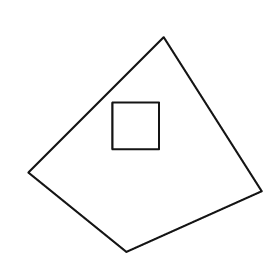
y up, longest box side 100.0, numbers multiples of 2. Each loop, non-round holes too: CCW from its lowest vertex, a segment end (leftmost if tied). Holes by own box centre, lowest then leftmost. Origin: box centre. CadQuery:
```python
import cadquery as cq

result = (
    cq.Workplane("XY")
    .moveTo(-8.0, -46.0)
    .lineTo(50.0, -20.0)
    .lineTo(8.0, 46.0)
    .lineTo(-50.0, -12.0)
    .close()
    .moveTo(-14.0, -2.0)
    .lineTo(6.0, -2.0)
    .lineTo(6.0, 18.0)
    .lineTo(-14.0, 18.0)
    .close()
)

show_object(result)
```